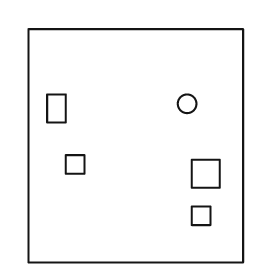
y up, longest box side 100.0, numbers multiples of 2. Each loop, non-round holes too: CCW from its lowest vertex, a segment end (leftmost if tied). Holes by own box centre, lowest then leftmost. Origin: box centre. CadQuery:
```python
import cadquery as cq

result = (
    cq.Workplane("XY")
    .moveTo(-46.0, -50.0)
    .lineTo(46.0, -50.0)
    .lineTo(46.0, 50.0)
    .lineTo(-46.0, 50.0)
    .close()
    .moveTo(24.0, -34.0)
    .lineTo(32.0, -34.0)
    .lineTo(32.0, -26.0)
    .lineTo(24.0, -26.0)
    .close()
    .moveTo(24.0, -18.0)
    .lineTo(36.0, -18.0)
    .lineTo(36.0, -6.0)
    .lineTo(24.0, -6.0)
    .close()
    .moveTo(-30.0, -12.0)
    .lineTo(-22.0, -12.0)
    .lineTo(-22.0, -4.0)
    .lineTo(-30.0, -4.0)
    .close()
    .moveTo(-38.0, 10.0)
    .lineTo(-30.0, 10.0)
    .lineTo(-30.0, 22.0)
    .lineTo(-38.0, 22.0)
    .close()
    .moveTo(22.0, 18.0)
    .circle(4.0)
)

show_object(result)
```